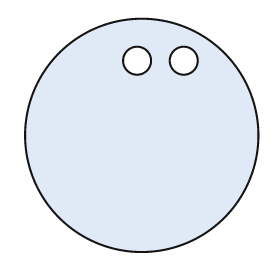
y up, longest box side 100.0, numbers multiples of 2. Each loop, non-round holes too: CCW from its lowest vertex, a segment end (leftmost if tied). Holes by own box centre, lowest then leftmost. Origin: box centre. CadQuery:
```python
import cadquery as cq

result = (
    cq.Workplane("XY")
    .moveTo(0.0, 0.0)
    .circle(50.0)
    .moveTo(-2.0, 32.0)
    .circle(6.0)
    .moveTo(18.0, 32.0)
    .circle(6.0)
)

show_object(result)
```